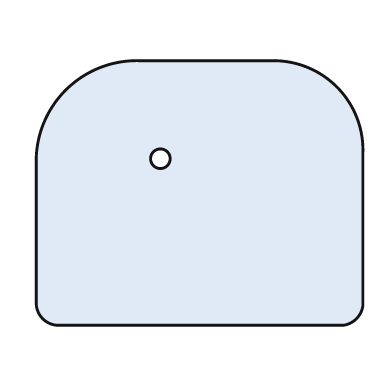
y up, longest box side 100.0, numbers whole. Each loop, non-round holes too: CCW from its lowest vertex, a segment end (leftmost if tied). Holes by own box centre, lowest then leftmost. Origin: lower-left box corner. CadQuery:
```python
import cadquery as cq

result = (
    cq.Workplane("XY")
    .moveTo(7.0, 0.0)
    .lineTo(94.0, 0.0)
    .threePointArc((98.0, 2.0), (100.0, 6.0))
    .lineTo(100.0, 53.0)
    .threePointArc((92.0, 73.0), (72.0, 81.0))
    .lineTo(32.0, 81.0)
    .threePointArc((9.0, 72.0), (0.0, 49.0))
    .lineTo(0.0, 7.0)
    .threePointArc((2.0, 2.0), (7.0, 0.0))
    .close()
    .moveTo(38.0, 51.0)
    .circle(3.0)
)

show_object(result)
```